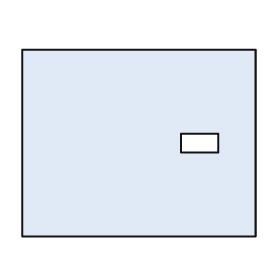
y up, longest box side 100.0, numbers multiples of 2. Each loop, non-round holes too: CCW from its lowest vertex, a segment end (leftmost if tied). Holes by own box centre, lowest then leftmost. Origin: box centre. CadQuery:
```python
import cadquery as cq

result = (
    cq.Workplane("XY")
    .moveTo(-50.0, -40.0)
    .lineTo(50.0, -40.0)
    .lineTo(50.0, 40.0)
    .lineTo(-50.0, 40.0)
    .close()
    .moveTo(18.0, -4.0)
    .lineTo(34.0, -4.0)
    .lineTo(34.0, 4.0)
    .lineTo(18.0, 4.0)
    .close()
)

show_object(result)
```